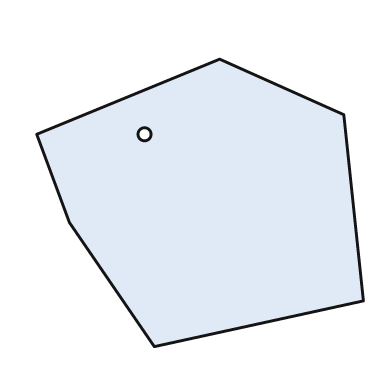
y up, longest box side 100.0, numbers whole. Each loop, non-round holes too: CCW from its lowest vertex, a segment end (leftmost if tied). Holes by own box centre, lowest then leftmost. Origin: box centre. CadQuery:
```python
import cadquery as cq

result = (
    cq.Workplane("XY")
    .moveTo(-14.0, -44.0)
    .lineTo(50.0, -30.0)
    .lineTo(44.0, 27.0)
    .lineTo(6.0, 44.0)
    .lineTo(-50.0, 21.0)
    .lineTo(-40.0, -6.0)
    .close()
    .moveTo(-17.0, 21.0)
    .circle(2.0)
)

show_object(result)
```